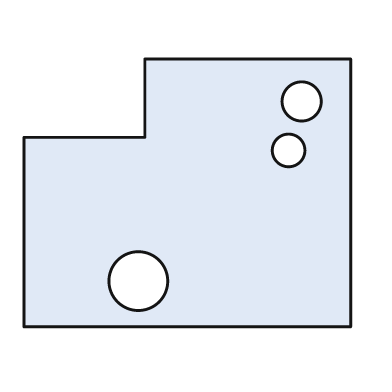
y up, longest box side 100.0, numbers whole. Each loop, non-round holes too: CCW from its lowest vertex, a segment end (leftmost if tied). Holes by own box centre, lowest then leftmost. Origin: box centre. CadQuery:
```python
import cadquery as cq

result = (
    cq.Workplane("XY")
    .moveTo(-50.0, -41.0)
    .lineTo(50.0, -41.0)
    .lineTo(50.0, 41.0)
    .lineTo(-13.0, 41.0)
    .lineTo(-13.0, 17.0)
    .lineTo(-50.0, 17.0)
    .close()
    .moveTo(-15.0, -27.0)
    .circle(9.0)
    .moveTo(31.0, 13.0)
    .circle(5.0)
    .moveTo(35.0, 28.0)
    .circle(6.0)
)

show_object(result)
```